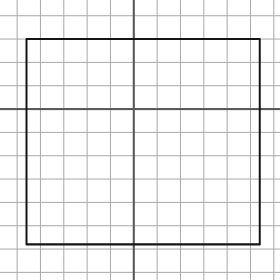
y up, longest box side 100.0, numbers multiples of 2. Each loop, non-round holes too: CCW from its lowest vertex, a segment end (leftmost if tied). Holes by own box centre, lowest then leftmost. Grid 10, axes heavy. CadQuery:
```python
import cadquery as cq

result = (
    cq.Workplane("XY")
    .moveTo(-46.0, -58.0)
    .lineTo(54.0, -58.0)
    .lineTo(54.0, 30.0)
    .lineTo(-46.0, 30.0)
    .close()
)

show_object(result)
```